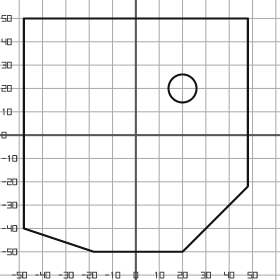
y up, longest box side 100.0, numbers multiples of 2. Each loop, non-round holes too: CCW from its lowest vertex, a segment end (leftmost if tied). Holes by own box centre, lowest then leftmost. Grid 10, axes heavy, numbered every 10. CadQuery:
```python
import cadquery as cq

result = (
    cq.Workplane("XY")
    .moveTo(-18.0, -50.0)
    .lineTo(20.0, -50.0)
    .lineTo(48.0, -22.0)
    .lineTo(48.0, 50.0)
    .lineTo(-48.0, 50.0)
    .lineTo(-48.0, -40.0)
    .close()
    .moveTo(20.0, 20.0)
    .circle(6.0)
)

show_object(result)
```